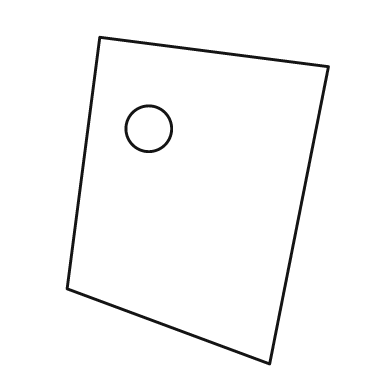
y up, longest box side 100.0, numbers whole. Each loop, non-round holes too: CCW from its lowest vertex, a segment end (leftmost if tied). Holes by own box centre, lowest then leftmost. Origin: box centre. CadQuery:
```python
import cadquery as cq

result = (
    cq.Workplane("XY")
    .moveTo(22.0, -50.0)
    .lineTo(40.0, 41.0)
    .lineTo(-30.0, 50.0)
    .lineTo(-40.0, -27.0)
    .close()
    .moveTo(-15.0, 22.0)
    .circle(7.0)
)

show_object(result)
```